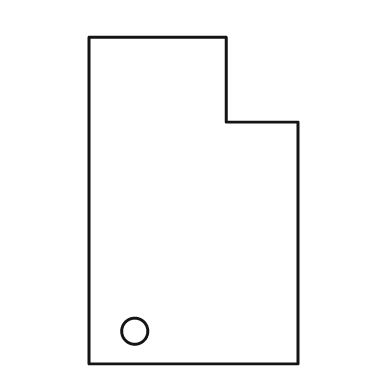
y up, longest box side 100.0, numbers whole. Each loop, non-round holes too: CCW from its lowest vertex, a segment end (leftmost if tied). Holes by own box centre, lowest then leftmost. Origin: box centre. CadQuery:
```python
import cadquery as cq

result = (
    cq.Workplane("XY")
    .moveTo(-32.0, -50.0)
    .lineTo(32.0, -50.0)
    .lineTo(32.0, 24.0)
    .lineTo(10.0, 24.0)
    .lineTo(10.0, 50.0)
    .lineTo(-32.0, 50.0)
    .close()
    .moveTo(-18.0, -40.0)
    .circle(4.0)
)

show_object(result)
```